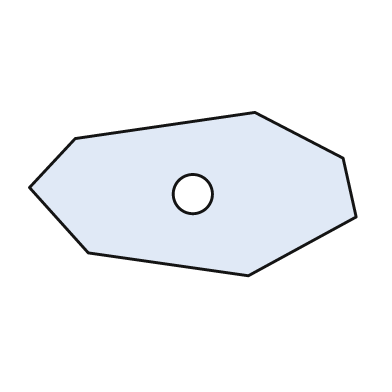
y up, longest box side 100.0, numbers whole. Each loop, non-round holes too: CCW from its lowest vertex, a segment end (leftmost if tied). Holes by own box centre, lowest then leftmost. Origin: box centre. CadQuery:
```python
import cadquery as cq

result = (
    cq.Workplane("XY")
    .moveTo(17.0, -25.0)
    .lineTo(50.0, -7.0)
    .lineTo(46.0, 11.0)
    .lineTo(19.0, 25.0)
    .lineTo(-36.0, 17.0)
    .lineTo(-50.0, 2.0)
    .lineTo(-32.0, -18.0)
    .close()
    .moveTo(0.0, 0.0)
    .circle(6.0)
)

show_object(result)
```